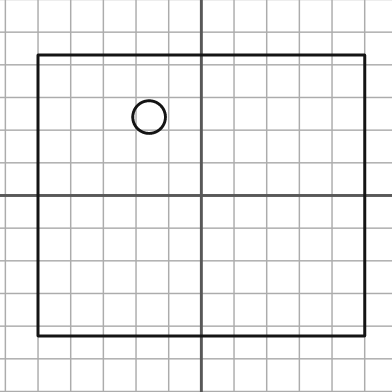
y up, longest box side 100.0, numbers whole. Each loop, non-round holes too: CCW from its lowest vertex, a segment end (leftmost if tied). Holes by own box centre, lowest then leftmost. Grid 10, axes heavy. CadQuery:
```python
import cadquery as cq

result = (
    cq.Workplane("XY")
    .moveTo(-50.0, -43.0)
    .lineTo(50.0, -43.0)
    .lineTo(50.0, 43.0)
    .lineTo(-50.0, 43.0)
    .close()
    .moveTo(-16.0, 24.0)
    .circle(5.0)
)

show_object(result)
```